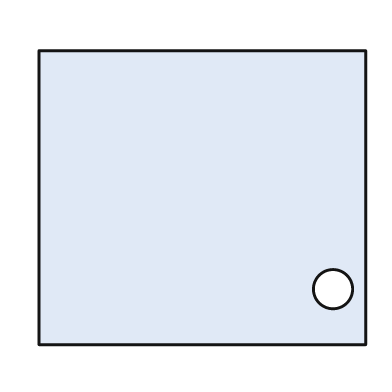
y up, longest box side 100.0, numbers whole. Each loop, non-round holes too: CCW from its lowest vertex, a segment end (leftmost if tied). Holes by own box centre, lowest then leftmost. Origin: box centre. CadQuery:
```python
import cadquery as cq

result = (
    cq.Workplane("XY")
    .moveTo(-50.0, -45.0)
    .lineTo(50.0, -45.0)
    .lineTo(50.0, 45.0)
    .lineTo(-50.0, 45.0)
    .close()
    .moveTo(40.0, -28.0)
    .circle(6.0)
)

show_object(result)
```